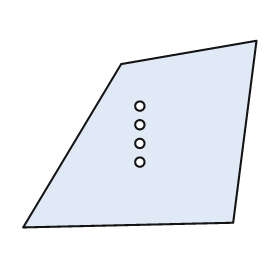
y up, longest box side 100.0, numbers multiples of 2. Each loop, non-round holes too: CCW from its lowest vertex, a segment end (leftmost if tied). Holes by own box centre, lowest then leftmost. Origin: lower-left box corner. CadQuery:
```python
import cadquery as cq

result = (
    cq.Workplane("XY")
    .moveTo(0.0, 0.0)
    .lineTo(90.0, 2.0)
    .lineTo(100.0, 80.0)
    .lineTo(42.0, 70.0)
    .close()
    .moveTo(50.0, 28.0)
    .circle(2.0)
    .moveTo(50.0, 36.0)
    .circle(2.0)
    .moveTo(50.0, 44.0)
    .circle(2.0)
    .moveTo(50.0, 52.0)
    .circle(2.0)
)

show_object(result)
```